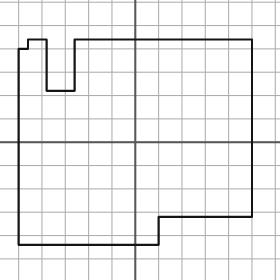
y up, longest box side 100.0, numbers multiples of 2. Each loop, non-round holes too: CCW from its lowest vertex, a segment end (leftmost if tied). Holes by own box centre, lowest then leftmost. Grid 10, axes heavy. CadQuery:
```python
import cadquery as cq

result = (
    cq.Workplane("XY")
    .moveTo(-50.0, -44.0)
    .lineTo(10.0, -44.0)
    .lineTo(10.0, -32.0)
    .lineTo(50.0, -32.0)
    .lineTo(50.0, 44.0)
    .lineTo(-26.0, 44.0)
    .lineTo(-26.0, 22.0)
    .lineTo(-38.0, 22.0)
    .lineTo(-38.0, 44.0)
    .lineTo(-46.0, 44.0)
    .lineTo(-46.0, 40.0)
    .lineTo(-50.0, 40.0)
    .close()
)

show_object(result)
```